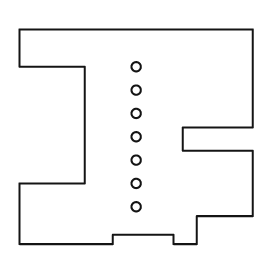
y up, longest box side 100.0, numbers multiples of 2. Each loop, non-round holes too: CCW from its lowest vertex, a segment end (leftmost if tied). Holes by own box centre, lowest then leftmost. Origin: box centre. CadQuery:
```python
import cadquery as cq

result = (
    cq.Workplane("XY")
    .moveTo(-50.0, -46.0)
    .lineTo(-10.0, -46.0)
    .lineTo(-10.0, -42.0)
    .lineTo(16.0, -42.0)
    .lineTo(16.0, -46.0)
    .lineTo(26.0, -46.0)
    .lineTo(26.0, -34.0)
    .lineTo(50.0, -34.0)
    .lineTo(50.0, -6.0)
    .lineTo(20.0, -6.0)
    .lineTo(20.0, 4.0)
    .lineTo(50.0, 4.0)
    .lineTo(50.0, 46.0)
    .lineTo(-50.0, 46.0)
    .lineTo(-50.0, 30.0)
    .lineTo(-22.0, 30.0)
    .lineTo(-22.0, -20.0)
    .lineTo(-50.0, -20.0)
    .close()
    .moveTo(0.0, -30.0)
    .circle(2.0)
    .moveTo(0.0, -20.0)
    .circle(2.0)
    .moveTo(0.0, -10.0)
    .circle(2.0)
    .moveTo(0.0, 0.0)
    .circle(2.0)
    .moveTo(0.0, 10.0)
    .circle(2.0)
    .moveTo(0.0, 20.0)
    .circle(2.0)
    .moveTo(0.0, 30.0)
    .circle(2.0)
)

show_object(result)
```